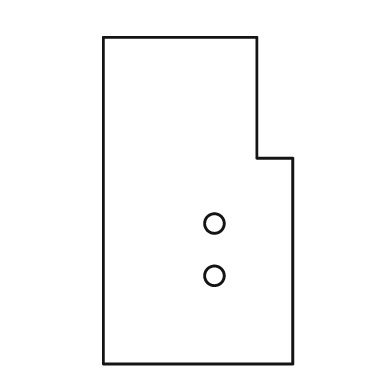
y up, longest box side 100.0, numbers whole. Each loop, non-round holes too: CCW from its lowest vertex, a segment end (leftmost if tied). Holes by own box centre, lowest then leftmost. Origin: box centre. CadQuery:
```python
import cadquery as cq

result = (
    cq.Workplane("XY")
    .moveTo(-29.0, -50.0)
    .lineTo(29.0, -50.0)
    .lineTo(29.0, 13.0)
    .lineTo(18.0, 13.0)
    .lineTo(18.0, 50.0)
    .lineTo(-29.0, 50.0)
    .close()
    .moveTo(5.0, -23.0)
    .circle(3.0)
    .moveTo(5.0, -7.0)
    .circle(3.0)
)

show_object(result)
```